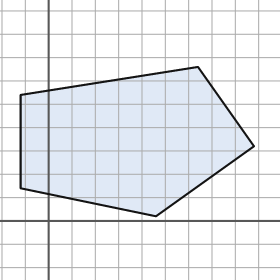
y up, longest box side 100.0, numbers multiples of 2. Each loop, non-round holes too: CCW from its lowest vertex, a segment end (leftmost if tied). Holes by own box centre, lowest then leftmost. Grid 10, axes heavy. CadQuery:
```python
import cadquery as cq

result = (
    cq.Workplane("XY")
    .moveTo(46.0, 2.0)
    .lineTo(88.0, 32.0)
    .lineTo(64.0, 66.0)
    .lineTo(-12.0, 54.0)
    .lineTo(-12.0, 14.0)
    .close()
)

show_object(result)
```